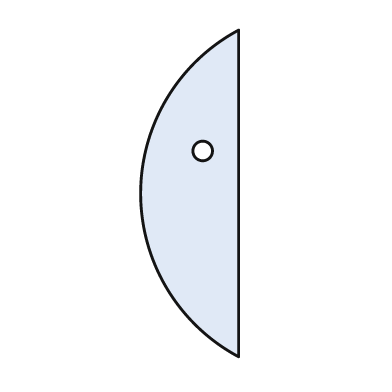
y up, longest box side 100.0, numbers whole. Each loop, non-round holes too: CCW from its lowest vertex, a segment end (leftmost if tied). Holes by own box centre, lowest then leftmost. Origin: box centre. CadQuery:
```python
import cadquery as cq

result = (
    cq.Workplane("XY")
    .moveTo(15.0, -50.0)
    .lineTo(15.0, 50.0)
    .threePointArc((-15.0, 0.0), (15.0, -50.0))
    .close()
    .moveTo(4.0, 13.0)
    .circle(3.0)
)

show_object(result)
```